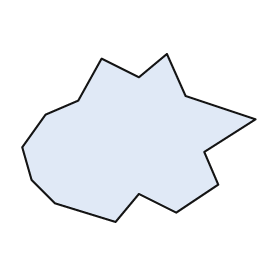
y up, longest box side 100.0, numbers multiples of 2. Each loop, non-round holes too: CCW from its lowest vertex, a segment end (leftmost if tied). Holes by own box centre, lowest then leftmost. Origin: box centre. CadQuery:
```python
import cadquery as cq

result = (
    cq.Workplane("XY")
    .moveTo(-10.0, -36.0)
    .lineTo(0.0, -24.0)
    .lineTo(16.0, -32.0)
    .lineTo(34.0, -20.0)
    .lineTo(28.0, -6.0)
    .lineTo(50.0, 8.0)
    .lineTo(20.0, 18.0)
    .lineTo(12.0, 36.0)
    .lineTo(0.0, 26.0)
    .lineTo(-16.0, 34.0)
    .lineTo(-26.0, 16.0)
    .lineTo(-40.0, 10.0)
    .lineTo(-50.0, -4.0)
    .lineTo(-46.0, -18.0)
    .lineTo(-36.0, -28.0)
    .close()
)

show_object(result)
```